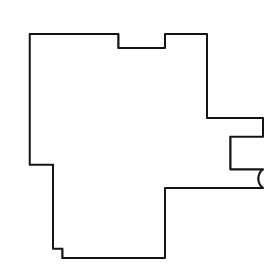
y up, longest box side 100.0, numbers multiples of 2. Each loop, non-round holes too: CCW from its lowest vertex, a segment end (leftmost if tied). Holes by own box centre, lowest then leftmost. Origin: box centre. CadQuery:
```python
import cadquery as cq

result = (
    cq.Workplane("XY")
    .moveTo(-36.0, -48.0)
    .lineTo(8.0, -48.0)
    .lineTo(8.0, -18.0)
    .lineTo(50.0, -18.0)
    .threePointArc((48.0, -14.0), (50.0, -10.0))
    .lineTo(36.0, -10.0)
    .lineTo(36.0, 4.0)
    .lineTo(50.0, 4.0)
    .lineTo(50.0, 12.0)
    .lineTo(26.0, 12.0)
    .lineTo(26.0, 48.0)
    .lineTo(8.0, 48.0)
    .lineTo(8.0, 42.0)
    .lineTo(-12.0, 42.0)
    .lineTo(-12.0, 48.0)
    .lineTo(-50.0, 48.0)
    .lineTo(-50.0, -8.0)
    .lineTo(-40.0, -8.0)
    .lineTo(-40.0, -44.0)
    .lineTo(-36.0, -44.0)
    .close()
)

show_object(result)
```